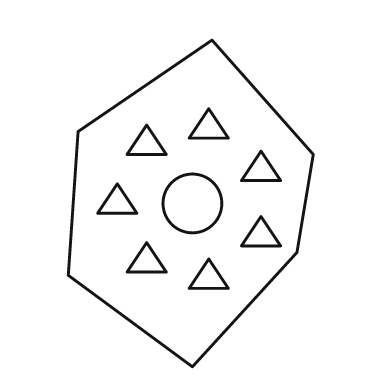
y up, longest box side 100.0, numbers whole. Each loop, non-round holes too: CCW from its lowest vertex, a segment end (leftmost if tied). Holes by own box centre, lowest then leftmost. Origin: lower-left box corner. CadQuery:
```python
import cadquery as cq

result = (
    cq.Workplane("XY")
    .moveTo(38.0, 0.0)
    .lineTo(70.0, 35.0)
    .lineTo(75.0, 65.0)
    .lineTo(44.0, 100.0)
    .lineTo(3.0, 72.0)
    .lineTo(0.0, 28.0)
    .close()
    .moveTo(37.0, 24.0)
    .lineTo(49.0, 24.0)
    .lineTo(43.0, 33.0)
    .close()
    .moveTo(18.0, 29.0)
    .lineTo(30.0, 29.0)
    .lineTo(24.0, 38.0)
    .close()
    .moveTo(53.0, 37.0)
    .lineTo(65.0, 37.0)
    .lineTo(59.0, 46.0)
    .close()
    .moveTo(38.0, 50.0)
    .circle(9.0)
    .moveTo(9.0, 47.0)
    .lineTo(21.0, 47.0)
    .lineTo(15.0, 56.0)
    .close()
    .moveTo(53.0, 57.0)
    .lineTo(65.0, 57.0)
    .lineTo(59.0, 66.0)
    .close()
    .moveTo(18.0, 65.0)
    .lineTo(30.0, 65.0)
    .lineTo(24.0, 74.0)
    .close()
    .moveTo(37.0, 70.0)
    .lineTo(49.0, 70.0)
    .lineTo(43.0, 79.0)
    .close()
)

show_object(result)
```